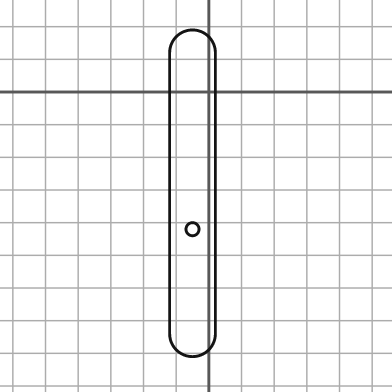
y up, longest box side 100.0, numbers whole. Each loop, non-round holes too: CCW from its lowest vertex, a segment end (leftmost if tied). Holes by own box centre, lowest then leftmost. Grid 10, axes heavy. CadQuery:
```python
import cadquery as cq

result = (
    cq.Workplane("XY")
    .moveTo(-12.0, -74.0)
    .threePointArc((-5.0, -81.0), (2.0, -74.0))
    .lineTo(2.0, 12.0)
    .threePointArc((-5.0, 19.0), (-12.0, 12.0))
    .close()
    .moveTo(-5.0, -42.0)
    .circle(2.0)
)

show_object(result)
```